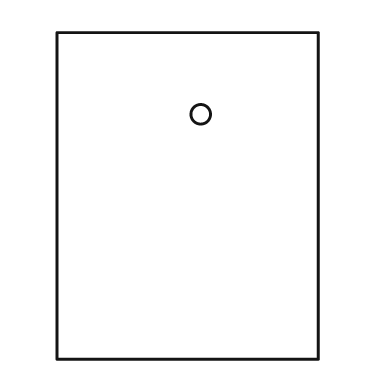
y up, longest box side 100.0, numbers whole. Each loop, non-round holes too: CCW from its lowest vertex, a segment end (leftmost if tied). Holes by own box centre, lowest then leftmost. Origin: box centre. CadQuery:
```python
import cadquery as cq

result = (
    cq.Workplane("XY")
    .moveTo(-40.0, -50.0)
    .lineTo(40.0, -50.0)
    .lineTo(40.0, 50.0)
    .lineTo(-40.0, 50.0)
    .close()
    .moveTo(4.0, 25.0)
    .circle(3.0)
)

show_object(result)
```